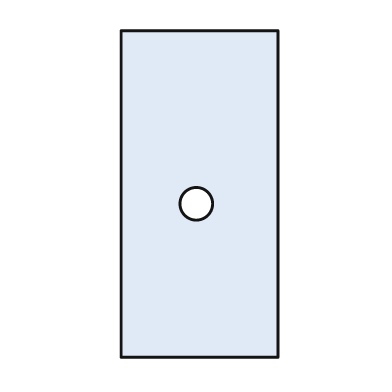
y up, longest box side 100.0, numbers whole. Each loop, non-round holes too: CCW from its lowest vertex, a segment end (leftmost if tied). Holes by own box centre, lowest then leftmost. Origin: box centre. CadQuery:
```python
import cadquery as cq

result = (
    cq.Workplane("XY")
    .moveTo(-24.0, -50.0)
    .lineTo(24.0, -50.0)
    .lineTo(24.0, 50.0)
    .lineTo(-24.0, 50.0)
    .close()
    .moveTo(-1.0, -3.0)
    .circle(5.0)
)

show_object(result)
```